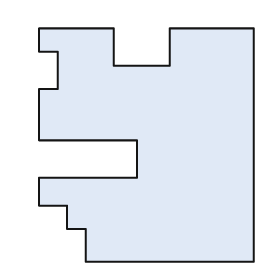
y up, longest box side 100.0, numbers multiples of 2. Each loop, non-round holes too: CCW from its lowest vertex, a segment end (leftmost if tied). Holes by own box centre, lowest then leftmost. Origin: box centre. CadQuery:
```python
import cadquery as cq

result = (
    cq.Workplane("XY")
    .moveTo(-26.0, -50.0)
    .lineTo(46.0, -50.0)
    .lineTo(46.0, 50.0)
    .lineTo(10.0, 50.0)
    .lineTo(10.0, 34.0)
    .lineTo(-14.0, 34.0)
    .lineTo(-14.0, 50.0)
    .lineTo(-46.0, 50.0)
    .lineTo(-46.0, 40.0)
    .lineTo(-38.0, 40.0)
    .lineTo(-38.0, 24.0)
    .lineTo(-46.0, 24.0)
    .lineTo(-46.0, 2.0)
    .lineTo(-4.0, 2.0)
    .lineTo(-4.0, -14.0)
    .lineTo(-46.0, -14.0)
    .lineTo(-46.0, -26.0)
    .lineTo(-34.0, -26.0)
    .lineTo(-34.0, -36.0)
    .lineTo(-26.0, -36.0)
    .close()
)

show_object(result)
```